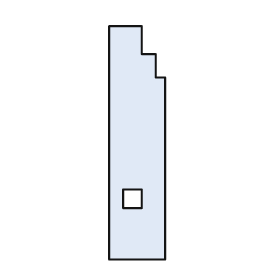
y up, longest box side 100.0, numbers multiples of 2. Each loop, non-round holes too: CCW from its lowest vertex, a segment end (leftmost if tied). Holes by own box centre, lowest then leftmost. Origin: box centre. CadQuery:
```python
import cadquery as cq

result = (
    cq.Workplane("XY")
    .moveTo(-12.0, -50.0)
    .lineTo(12.0, -50.0)
    .lineTo(12.0, 28.0)
    .lineTo(8.0, 28.0)
    .lineTo(8.0, 38.0)
    .lineTo(2.0, 38.0)
    .lineTo(2.0, 50.0)
    .lineTo(-12.0, 50.0)
    .close()
    .moveTo(-6.0, -28.0)
    .lineTo(2.0, -28.0)
    .lineTo(2.0, -20.0)
    .lineTo(-6.0, -20.0)
    .close()
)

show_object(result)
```